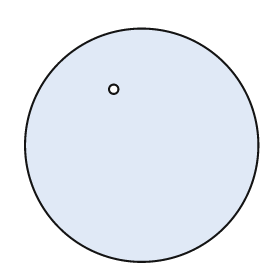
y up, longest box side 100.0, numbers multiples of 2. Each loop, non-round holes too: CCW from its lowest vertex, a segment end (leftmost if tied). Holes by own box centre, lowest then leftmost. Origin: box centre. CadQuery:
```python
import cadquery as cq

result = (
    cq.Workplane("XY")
    .moveTo(0.0, 0.0)
    .circle(50.0)
    .moveTo(-12.0, 24.0)
    .circle(2.0)
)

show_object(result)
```